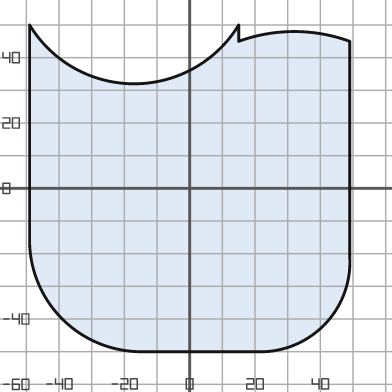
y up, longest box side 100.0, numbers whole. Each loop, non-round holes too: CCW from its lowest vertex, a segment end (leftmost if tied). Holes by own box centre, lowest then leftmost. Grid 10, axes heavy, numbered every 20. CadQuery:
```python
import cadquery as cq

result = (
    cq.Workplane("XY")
    .moveTo(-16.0, -50.0)
    .lineTo(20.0, -50.0)
    .threePointArc((41.0, -42.0), (49.0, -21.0))
    .lineTo(49.0, 45.0)
    .threePointArc((32.0, 48.0), (15.0, 45.0))
    .lineTo(15.0, 50.0)
    .threePointArc((-17.0, 32.0), (-49.0, 50.0))
    .lineTo(-49.0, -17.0)
    .threePointArc((-39.0, -40.0), (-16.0, -50.0))
    .close()
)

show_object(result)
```